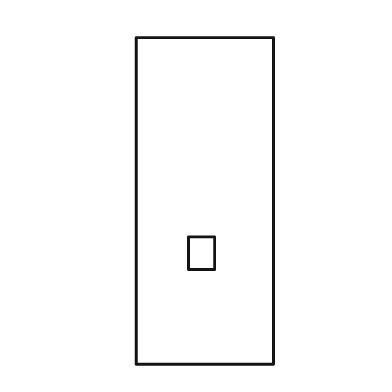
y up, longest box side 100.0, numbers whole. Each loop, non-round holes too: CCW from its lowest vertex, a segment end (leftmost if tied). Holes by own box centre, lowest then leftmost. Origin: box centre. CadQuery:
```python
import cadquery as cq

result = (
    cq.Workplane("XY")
    .moveTo(-21.0, -50.0)
    .lineTo(21.0, -50.0)
    .lineTo(21.0, 50.0)
    .lineTo(-21.0, 50.0)
    .close()
    .moveTo(-5.0, -21.0)
    .lineTo(3.0, -21.0)
    .lineTo(3.0, -11.0)
    .lineTo(-5.0, -11.0)
    .close()
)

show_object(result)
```